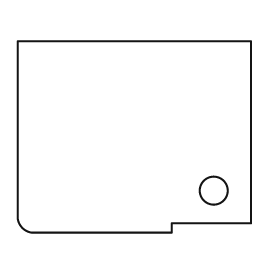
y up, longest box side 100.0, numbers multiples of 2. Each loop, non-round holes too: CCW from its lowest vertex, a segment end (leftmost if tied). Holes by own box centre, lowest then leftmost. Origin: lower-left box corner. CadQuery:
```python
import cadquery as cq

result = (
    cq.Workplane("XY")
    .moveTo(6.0, 0.0)
    .lineTo(66.0, 0.0)
    .lineTo(66.0, 4.0)
    .lineTo(100.0, 4.0)
    .lineTo(100.0, 82.0)
    .lineTo(0.0, 82.0)
    .lineTo(0.0, 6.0)
    .threePointArc((2.0, 2.0), (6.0, 0.0))
    .close()
    .moveTo(84.0, 18.0)
    .circle(6.0)
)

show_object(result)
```